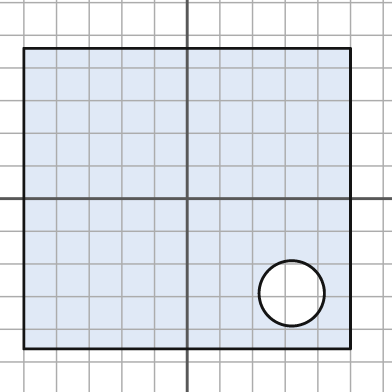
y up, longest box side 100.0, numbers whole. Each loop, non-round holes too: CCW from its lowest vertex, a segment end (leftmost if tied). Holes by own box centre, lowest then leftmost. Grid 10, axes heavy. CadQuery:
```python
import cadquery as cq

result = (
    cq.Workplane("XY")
    .moveTo(-50.0, -46.0)
    .lineTo(50.0, -46.0)
    .lineTo(50.0, 46.0)
    .lineTo(-50.0, 46.0)
    .close()
    .moveTo(32.0, -29.0)
    .circle(10.0)
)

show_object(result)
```